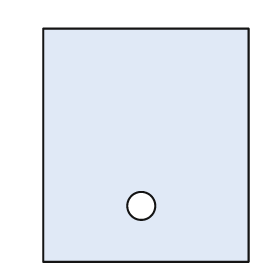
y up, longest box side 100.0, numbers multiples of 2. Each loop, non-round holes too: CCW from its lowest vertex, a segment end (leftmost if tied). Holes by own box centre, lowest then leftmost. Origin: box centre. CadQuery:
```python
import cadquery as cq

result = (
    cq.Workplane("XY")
    .moveTo(-44.0, -50.0)
    .lineTo(44.0, -50.0)
    .lineTo(44.0, 50.0)
    .lineTo(-44.0, 50.0)
    .close()
    .moveTo(-2.0, -26.0)
    .circle(6.0)
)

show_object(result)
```